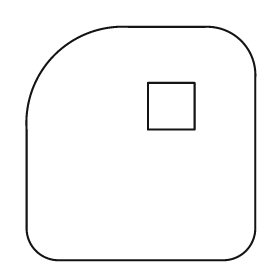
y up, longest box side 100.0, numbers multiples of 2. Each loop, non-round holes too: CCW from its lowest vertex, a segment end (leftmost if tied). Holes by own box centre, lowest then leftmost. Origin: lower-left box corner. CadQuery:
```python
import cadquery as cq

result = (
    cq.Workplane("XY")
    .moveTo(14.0, 0.0)
    .lineTo(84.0, 0.0)
    .threePointArc((94.0, 4.0), (98.0, 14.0))
    .lineTo(98.0, 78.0)
    .threePointArc((92.0, 94.0), (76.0, 100.0))
    .lineTo(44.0, 100.0)
    .threePointArc((12.0, 88.0), (0.0, 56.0))
    .lineTo(0.0, 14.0)
    .threePointArc((4.0, 4.0), (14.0, 0.0))
    .close()
    .moveTo(52.0, 56.0)
    .lineTo(72.0, 56.0)
    .lineTo(72.0, 76.0)
    .lineTo(52.0, 76.0)
    .close()
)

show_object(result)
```